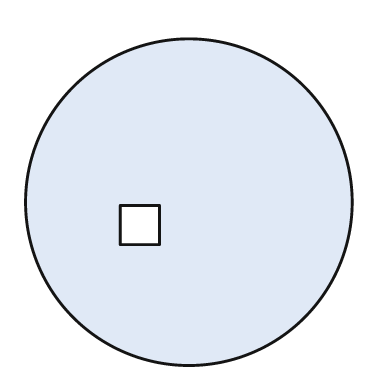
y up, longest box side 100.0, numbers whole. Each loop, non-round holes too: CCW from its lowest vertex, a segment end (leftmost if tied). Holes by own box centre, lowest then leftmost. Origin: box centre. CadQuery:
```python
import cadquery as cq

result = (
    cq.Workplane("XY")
    .moveTo(0.0, 0.0)
    .circle(50.0)
    .moveTo(-21.0, -13.0)
    .lineTo(-9.0, -13.0)
    .lineTo(-9.0, -1.0)
    .lineTo(-21.0, -1.0)
    .close()
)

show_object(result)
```